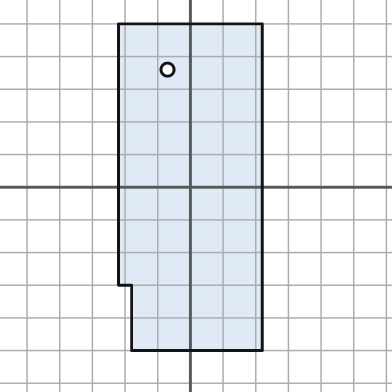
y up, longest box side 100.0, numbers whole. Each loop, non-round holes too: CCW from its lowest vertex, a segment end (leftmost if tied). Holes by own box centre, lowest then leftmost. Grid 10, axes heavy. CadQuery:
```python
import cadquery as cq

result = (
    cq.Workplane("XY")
    .moveTo(-18.0, -50.0)
    .lineTo(22.0, -50.0)
    .lineTo(22.0, 50.0)
    .lineTo(-22.0, 50.0)
    .lineTo(-22.0, -30.0)
    .lineTo(-18.0, -30.0)
    .close()
    .moveTo(-7.0, 36.0)
    .circle(2.0)
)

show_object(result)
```